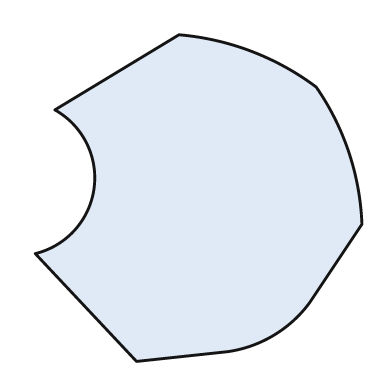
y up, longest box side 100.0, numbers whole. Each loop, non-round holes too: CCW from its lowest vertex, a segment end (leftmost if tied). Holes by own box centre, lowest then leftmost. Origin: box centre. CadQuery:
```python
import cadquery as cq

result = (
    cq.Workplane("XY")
    .moveTo(-19.0, -50.0)
    .lineTo(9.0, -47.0)
    .threePointArc((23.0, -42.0), (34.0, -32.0))
    .lineTo(50.0, -8.0)
    .threePointArc((46.0, 14.0), (36.0, 34.0))
    .threePointArc((16.0, 45.0), (-6.0, 50.0))
    .lineTo(-44.0, 27.0)
    .threePointArc((-32.0, 3.0), (-50.0, -17.0))
    .close()
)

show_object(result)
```